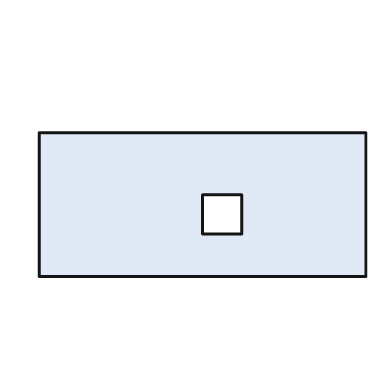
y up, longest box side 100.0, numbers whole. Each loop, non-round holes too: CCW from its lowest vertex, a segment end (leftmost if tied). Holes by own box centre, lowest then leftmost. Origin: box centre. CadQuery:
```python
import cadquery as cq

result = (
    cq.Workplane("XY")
    .moveTo(-50.0, -22.0)
    .lineTo(50.0, -22.0)
    .lineTo(50.0, 22.0)
    .lineTo(-50.0, 22.0)
    .close()
    .moveTo(0.0, -9.0)
    .lineTo(12.0, -9.0)
    .lineTo(12.0, 3.0)
    .lineTo(0.0, 3.0)
    .close()
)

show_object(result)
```